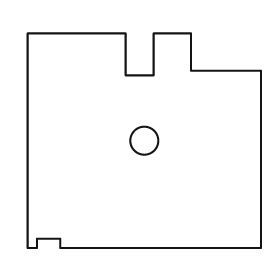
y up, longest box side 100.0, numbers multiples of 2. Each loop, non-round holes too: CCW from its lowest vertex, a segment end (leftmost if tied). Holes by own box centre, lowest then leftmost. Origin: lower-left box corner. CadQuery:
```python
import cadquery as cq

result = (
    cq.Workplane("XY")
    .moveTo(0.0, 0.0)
    .lineTo(4.0, 0.0)
    .lineTo(4.0, 4.0)
    .lineTo(14.0, 4.0)
    .lineTo(14.0, 0.0)
    .lineTo(100.0, 0.0)
    .lineTo(100.0, 76.0)
    .lineTo(70.0, 76.0)
    .lineTo(70.0, 92.0)
    .lineTo(54.0, 92.0)
    .lineTo(54.0, 74.0)
    .lineTo(42.0, 74.0)
    .lineTo(42.0, 92.0)
    .lineTo(0.0, 92.0)
    .close()
    .moveTo(50.0, 46.0)
    .circle(6.0)
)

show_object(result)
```